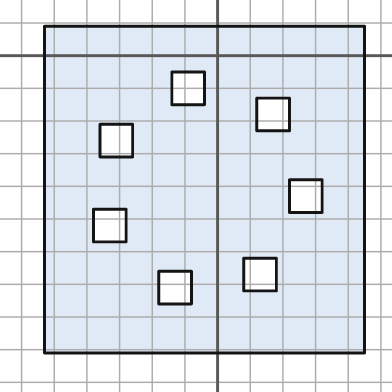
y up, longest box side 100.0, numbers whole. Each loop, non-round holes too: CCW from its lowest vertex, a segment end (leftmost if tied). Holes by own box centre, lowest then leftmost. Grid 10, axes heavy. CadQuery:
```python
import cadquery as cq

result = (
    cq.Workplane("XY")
    .moveTo(-53.0, -91.0)
    .lineTo(45.0, -91.0)
    .lineTo(45.0, 9.0)
    .lineTo(-53.0, 9.0)
    .close()
    .moveTo(-18.0, -76.0)
    .lineTo(-8.0, -76.0)
    .lineTo(-8.0, -66.0)
    .lineTo(-18.0, -66.0)
    .close()
    .moveTo(8.0, -72.0)
    .lineTo(18.0, -72.0)
    .lineTo(18.0, -62.0)
    .lineTo(8.0, -62.0)
    .close()
    .moveTo(-38.0, -57.0)
    .lineTo(-28.0, -57.0)
    .lineTo(-28.0, -47.0)
    .lineTo(-38.0, -47.0)
    .close()
    .moveTo(22.0, -48.0)
    .lineTo(32.0, -48.0)
    .lineTo(32.0, -38.0)
    .lineTo(22.0, -38.0)
    .close()
    .moveTo(-36.0, -31.0)
    .lineTo(-26.0, -31.0)
    .lineTo(-26.0, -21.0)
    .lineTo(-36.0, -21.0)
    .close()
    .moveTo(12.0, -23.0)
    .lineTo(22.0, -23.0)
    .lineTo(22.0, -13.0)
    .lineTo(12.0, -13.0)
    .close()
    .moveTo(-14.0, -15.0)
    .lineTo(-4.0, -15.0)
    .lineTo(-4.0, -5.0)
    .lineTo(-14.0, -5.0)
    .close()
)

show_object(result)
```